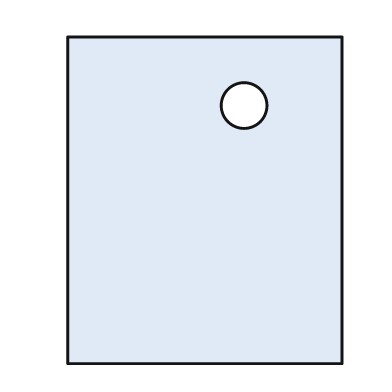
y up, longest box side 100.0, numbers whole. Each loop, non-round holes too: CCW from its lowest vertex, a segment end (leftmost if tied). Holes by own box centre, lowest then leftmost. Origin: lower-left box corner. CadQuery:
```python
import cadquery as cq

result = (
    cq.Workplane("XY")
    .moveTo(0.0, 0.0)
    .lineTo(84.0, 0.0)
    .lineTo(84.0, 100.0)
    .lineTo(0.0, 100.0)
    .close()
    .moveTo(54.0, 79.0)
    .circle(7.0)
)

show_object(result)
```